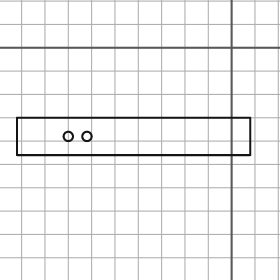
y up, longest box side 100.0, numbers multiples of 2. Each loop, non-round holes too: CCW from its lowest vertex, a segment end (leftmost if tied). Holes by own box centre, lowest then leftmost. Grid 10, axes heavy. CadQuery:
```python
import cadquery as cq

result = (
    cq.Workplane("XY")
    .moveTo(-92.0, -46.0)
    .lineTo(8.0, -46.0)
    .lineTo(8.0, -30.0)
    .lineTo(-92.0, -30.0)
    .close()
    .moveTo(-70.0, -38.0)
    .circle(2.0)
    .moveTo(-62.0, -38.0)
    .circle(2.0)
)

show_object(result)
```